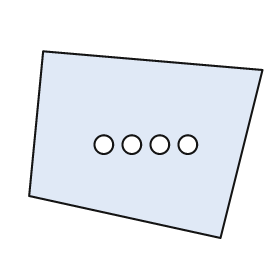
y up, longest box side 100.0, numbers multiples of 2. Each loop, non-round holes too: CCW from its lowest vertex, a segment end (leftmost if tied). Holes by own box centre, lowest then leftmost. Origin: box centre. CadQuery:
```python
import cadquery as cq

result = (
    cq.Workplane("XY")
    .moveTo(32.0, -40.0)
    .lineTo(50.0, 32.0)
    .lineTo(-44.0, 40.0)
    .lineTo(-50.0, -22.0)
    .close()
    .moveTo(-18.0, 0.0)
    .circle(4.0)
    .moveTo(-6.0, 0.0)
    .circle(4.0)
    .moveTo(6.0, 0.0)
    .circle(4.0)
    .moveTo(18.0, 0.0)
    .circle(4.0)
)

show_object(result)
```